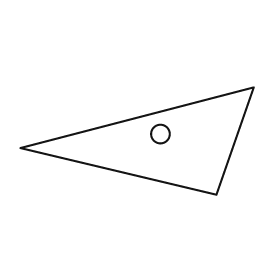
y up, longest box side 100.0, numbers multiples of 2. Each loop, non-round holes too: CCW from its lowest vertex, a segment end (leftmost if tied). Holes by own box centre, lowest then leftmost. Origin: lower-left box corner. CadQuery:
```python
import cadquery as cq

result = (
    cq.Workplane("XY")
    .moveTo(84.0, 0.0)
    .lineTo(100.0, 46.0)
    .lineTo(0.0, 20.0)
    .close()
    .moveTo(60.0, 26.0)
    .circle(4.0)
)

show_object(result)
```